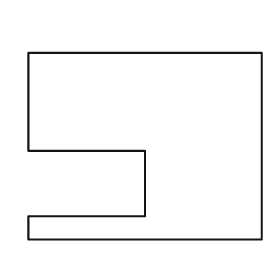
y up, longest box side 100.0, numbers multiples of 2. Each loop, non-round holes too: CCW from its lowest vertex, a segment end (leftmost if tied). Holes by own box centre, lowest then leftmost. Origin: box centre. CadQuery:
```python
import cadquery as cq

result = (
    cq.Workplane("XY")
    .moveTo(-50.0, -40.0)
    .lineTo(50.0, -40.0)
    .lineTo(50.0, 40.0)
    .lineTo(-50.0, 40.0)
    .lineTo(-50.0, -2.0)
    .lineTo(0.0, -2.0)
    .lineTo(0.0, -30.0)
    .lineTo(-50.0, -30.0)
    .close()
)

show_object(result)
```